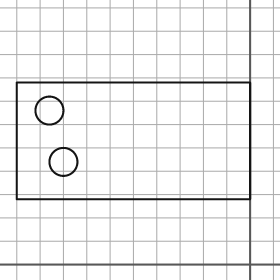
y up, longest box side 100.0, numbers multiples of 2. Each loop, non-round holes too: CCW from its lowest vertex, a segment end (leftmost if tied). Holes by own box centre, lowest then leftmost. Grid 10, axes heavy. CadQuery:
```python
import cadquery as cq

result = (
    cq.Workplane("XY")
    .moveTo(-100.0, 28.0)
    .lineTo(0.0, 28.0)
    .lineTo(0.0, 78.0)
    .lineTo(-100.0, 78.0)
    .close()
    .moveTo(-80.0, 44.0)
    .circle(6.0)
    .moveTo(-86.0, 66.0)
    .circle(6.0)
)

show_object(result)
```